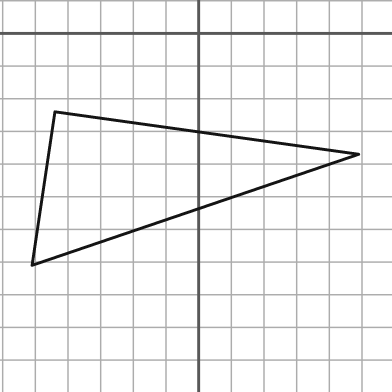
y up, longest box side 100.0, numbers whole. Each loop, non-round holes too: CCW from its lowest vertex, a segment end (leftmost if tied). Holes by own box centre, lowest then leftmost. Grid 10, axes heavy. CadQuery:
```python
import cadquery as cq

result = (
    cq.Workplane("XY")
    .moveTo(-51.0, -71.0)
    .lineTo(49.0, -37.0)
    .lineTo(-44.0, -24.0)
    .close()
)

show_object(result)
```